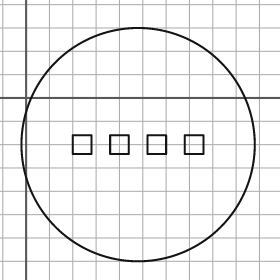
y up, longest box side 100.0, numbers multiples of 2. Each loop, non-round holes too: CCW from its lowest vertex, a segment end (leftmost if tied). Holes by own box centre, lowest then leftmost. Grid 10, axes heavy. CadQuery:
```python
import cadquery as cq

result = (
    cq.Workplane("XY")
    .moveTo(48.0, -20.0)
    .circle(50.0)
    .moveTo(20.0, -24.0)
    .lineTo(28.0, -24.0)
    .lineTo(28.0, -16.0)
    .lineTo(20.0, -16.0)
    .close()
    .moveTo(36.0, -24.0)
    .lineTo(44.0, -24.0)
    .lineTo(44.0, -16.0)
    .lineTo(36.0, -16.0)
    .close()
    .moveTo(52.0, -24.0)
    .lineTo(60.0, -24.0)
    .lineTo(60.0, -16.0)
    .lineTo(52.0, -16.0)
    .close()
    .moveTo(68.0, -24.0)
    .lineTo(76.0, -24.0)
    .lineTo(76.0, -16.0)
    .lineTo(68.0, -16.0)
    .close()
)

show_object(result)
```